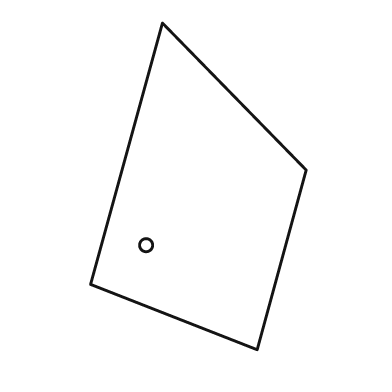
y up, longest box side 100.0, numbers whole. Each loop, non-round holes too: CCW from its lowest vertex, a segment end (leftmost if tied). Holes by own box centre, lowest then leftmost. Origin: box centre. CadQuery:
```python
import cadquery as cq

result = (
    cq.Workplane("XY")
    .moveTo(18.0, -50.0)
    .lineTo(33.0, 5.0)
    .lineTo(-11.0, 50.0)
    .lineTo(-33.0, -30.0)
    .close()
    .moveTo(-16.0, -18.0)
    .circle(2.0)
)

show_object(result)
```